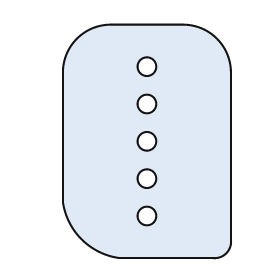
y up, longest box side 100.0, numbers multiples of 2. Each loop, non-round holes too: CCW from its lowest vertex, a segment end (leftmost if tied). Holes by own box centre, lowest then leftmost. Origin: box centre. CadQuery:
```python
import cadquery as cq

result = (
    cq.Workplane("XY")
    .moveTo(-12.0, -50.0)
    .lineTo(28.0, -50.0)
    .threePointArc((34.0, -48.0), (36.0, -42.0))
    .lineTo(36.0, 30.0)
    .threePointArc((30.0, 44.0), (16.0, 50.0))
    .lineTo(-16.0, 50.0)
    .threePointArc((-30.0, 44.0), (-36.0, 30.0))
    .lineTo(-36.0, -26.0)
    .threePointArc((-28.0, -42.0), (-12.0, -50.0))
    .close()
    .moveTo(0.0, -32.0)
    .circle(4.0)
    .moveTo(0.0, -16.0)
    .circle(4.0)
    .moveTo(0.0, 0.0)
    .circle(4.0)
    .moveTo(0.0, 16.0)
    .circle(4.0)
    .moveTo(0.0, 32.0)
    .circle(4.0)
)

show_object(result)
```